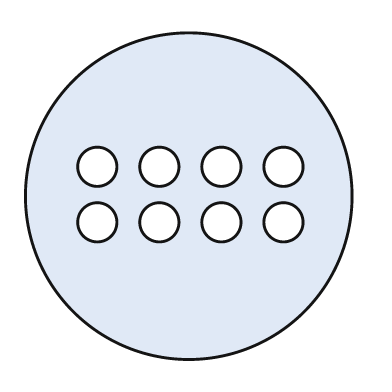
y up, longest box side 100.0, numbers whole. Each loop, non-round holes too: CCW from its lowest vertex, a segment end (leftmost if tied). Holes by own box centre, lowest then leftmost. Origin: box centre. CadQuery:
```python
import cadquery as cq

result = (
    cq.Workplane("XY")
    .moveTo(0.0, 0.0)
    .circle(50.0)
    .moveTo(-28.0, -8.0)
    .circle(6.0)
    .moveTo(-9.0, -8.0)
    .circle(6.0)
    .moveTo(10.0, -8.0)
    .circle(6.0)
    .moveTo(29.0, -8.0)
    .circle(6.0)
    .moveTo(-28.0, 9.0)
    .circle(6.0)
    .moveTo(-9.0, 9.0)
    .circle(6.0)
    .moveTo(10.0, 9.0)
    .circle(6.0)
    .moveTo(29.0, 9.0)
    .circle(6.0)
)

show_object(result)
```